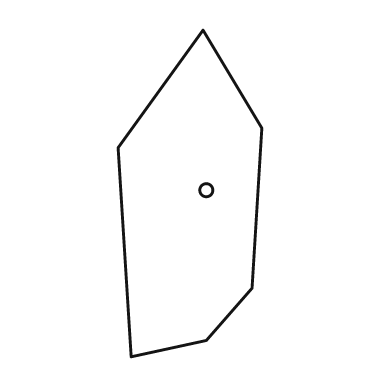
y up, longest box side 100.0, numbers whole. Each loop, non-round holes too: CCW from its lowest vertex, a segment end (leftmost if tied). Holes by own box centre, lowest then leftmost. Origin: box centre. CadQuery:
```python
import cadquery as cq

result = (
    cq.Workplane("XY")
    .moveTo(-18.0, -50.0)
    .lineTo(5.0, -45.0)
    .lineTo(19.0, -29.0)
    .lineTo(22.0, 20.0)
    .lineTo(4.0, 50.0)
    .lineTo(-22.0, 14.0)
    .close()
    .moveTo(5.0, 1.0)
    .circle(2.0)
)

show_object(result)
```